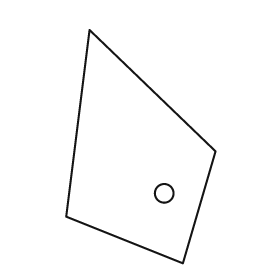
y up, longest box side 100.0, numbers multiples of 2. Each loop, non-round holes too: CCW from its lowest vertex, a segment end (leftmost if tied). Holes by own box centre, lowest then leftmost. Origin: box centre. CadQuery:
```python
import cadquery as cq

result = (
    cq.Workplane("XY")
    .moveTo(18.0, -50.0)
    .lineTo(32.0, -2.0)
    .lineTo(-22.0, 50.0)
    .lineTo(-32.0, -30.0)
    .close()
    .moveTo(10.0, -20.0)
    .circle(4.0)
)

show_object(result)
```